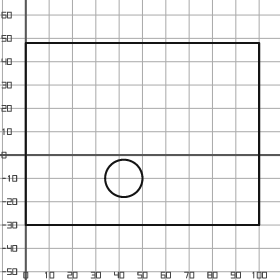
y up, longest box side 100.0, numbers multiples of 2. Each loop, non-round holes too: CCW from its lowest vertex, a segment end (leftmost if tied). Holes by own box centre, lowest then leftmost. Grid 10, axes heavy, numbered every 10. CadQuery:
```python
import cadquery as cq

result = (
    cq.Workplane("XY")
    .moveTo(0.0, -30.0)
    .lineTo(100.0, -30.0)
    .lineTo(100.0, 48.0)
    .lineTo(0.0, 48.0)
    .close()
    .moveTo(42.0, -10.0)
    .circle(8.0)
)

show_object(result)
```